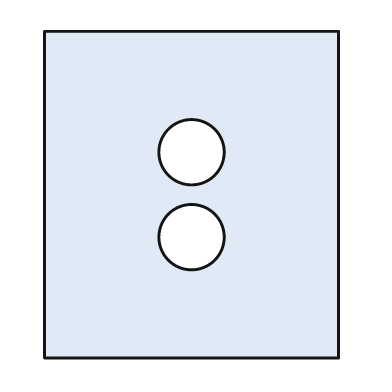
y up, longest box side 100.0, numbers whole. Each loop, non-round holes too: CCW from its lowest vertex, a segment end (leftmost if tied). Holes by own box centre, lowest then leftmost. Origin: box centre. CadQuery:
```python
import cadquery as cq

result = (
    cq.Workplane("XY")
    .moveTo(-45.0, -50.0)
    .lineTo(45.0, -50.0)
    .lineTo(45.0, 50.0)
    .lineTo(-45.0, 50.0)
    .close()
    .moveTo(0.0, -13.0)
    .circle(10.0)
    .moveTo(0.0, 13.0)
    .circle(10.0)
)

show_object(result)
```